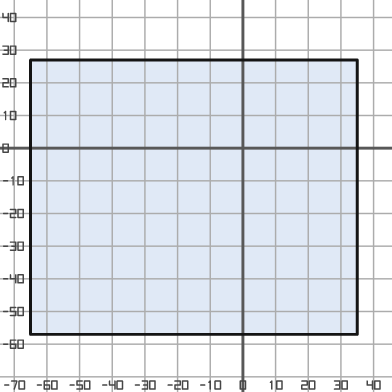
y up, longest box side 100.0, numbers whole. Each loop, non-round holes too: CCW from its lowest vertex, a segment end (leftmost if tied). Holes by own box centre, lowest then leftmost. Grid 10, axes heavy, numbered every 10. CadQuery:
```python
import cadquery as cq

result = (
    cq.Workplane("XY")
    .moveTo(-65.0, -57.0)
    .lineTo(35.0, -57.0)
    .lineTo(35.0, 27.0)
    .lineTo(-65.0, 27.0)
    .close()
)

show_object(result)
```